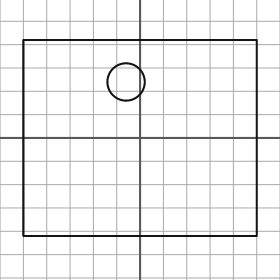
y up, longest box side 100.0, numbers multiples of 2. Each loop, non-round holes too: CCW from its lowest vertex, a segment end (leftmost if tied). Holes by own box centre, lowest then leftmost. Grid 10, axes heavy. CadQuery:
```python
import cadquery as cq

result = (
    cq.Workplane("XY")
    .moveTo(-50.0, -42.0)
    .lineTo(50.0, -42.0)
    .lineTo(50.0, 42.0)
    .lineTo(-50.0, 42.0)
    .close()
    .moveTo(-6.0, 24.0)
    .circle(8.0)
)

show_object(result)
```